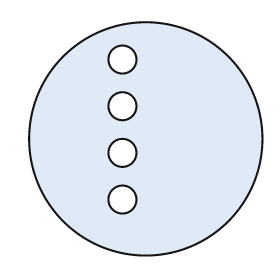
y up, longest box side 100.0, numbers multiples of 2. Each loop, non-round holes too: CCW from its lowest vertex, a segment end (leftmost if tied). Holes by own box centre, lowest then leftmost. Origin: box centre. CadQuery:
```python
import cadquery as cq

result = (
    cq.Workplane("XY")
    .moveTo(0.0, 0.0)
    .circle(50.0)
    .moveTo(-10.0, -26.0)
    .circle(6.0)
    .moveTo(-10.0, -6.0)
    .circle(6.0)
    .moveTo(-10.0, 14.0)
    .circle(6.0)
    .moveTo(-10.0, 34.0)
    .circle(6.0)
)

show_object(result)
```